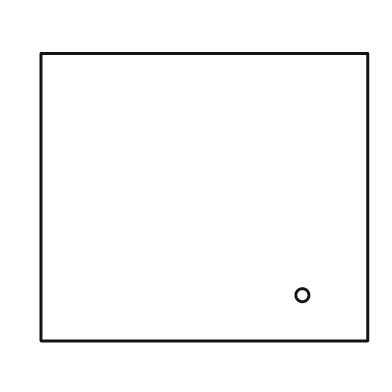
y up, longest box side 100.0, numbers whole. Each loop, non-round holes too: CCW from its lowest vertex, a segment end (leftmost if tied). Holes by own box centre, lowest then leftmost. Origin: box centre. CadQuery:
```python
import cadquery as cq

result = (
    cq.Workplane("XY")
    .moveTo(-50.0, -44.0)
    .lineTo(50.0, -44.0)
    .lineTo(50.0, 44.0)
    .lineTo(-50.0, 44.0)
    .close()
    .moveTo(30.0, -30.0)
    .circle(2.0)
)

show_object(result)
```